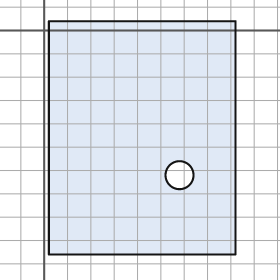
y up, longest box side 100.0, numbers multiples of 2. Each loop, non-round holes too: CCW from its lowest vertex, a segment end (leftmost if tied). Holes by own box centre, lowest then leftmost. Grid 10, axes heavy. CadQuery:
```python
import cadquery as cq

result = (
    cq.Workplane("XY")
    .moveTo(2.0, -96.0)
    .lineTo(82.0, -96.0)
    .lineTo(82.0, 4.0)
    .lineTo(2.0, 4.0)
    .close()
    .moveTo(58.0, -62.0)
    .circle(6.0)
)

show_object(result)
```